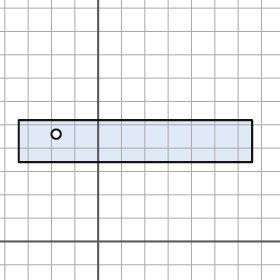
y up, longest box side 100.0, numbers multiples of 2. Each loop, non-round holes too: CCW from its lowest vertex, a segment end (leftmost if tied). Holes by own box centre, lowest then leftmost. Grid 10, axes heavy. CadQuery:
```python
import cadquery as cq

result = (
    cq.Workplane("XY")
    .moveTo(-34.0, 34.0)
    .lineTo(66.0, 34.0)
    .lineTo(66.0, 52.0)
    .lineTo(-34.0, 52.0)
    .close()
    .moveTo(-18.0, 46.0)
    .circle(2.0)
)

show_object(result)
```